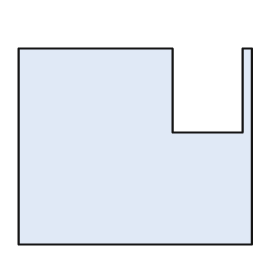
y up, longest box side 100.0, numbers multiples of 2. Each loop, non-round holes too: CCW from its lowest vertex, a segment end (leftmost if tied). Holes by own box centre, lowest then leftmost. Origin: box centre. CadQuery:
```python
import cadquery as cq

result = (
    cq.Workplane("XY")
    .moveTo(-50.0, -42.0)
    .lineTo(50.0, -42.0)
    .lineTo(50.0, 42.0)
    .lineTo(46.0, 42.0)
    .lineTo(46.0, 6.0)
    .lineTo(16.0, 6.0)
    .lineTo(16.0, 42.0)
    .lineTo(-50.0, 42.0)
    .close()
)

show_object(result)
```